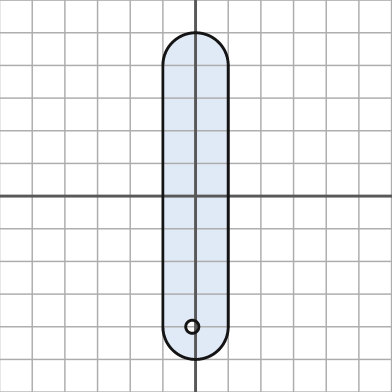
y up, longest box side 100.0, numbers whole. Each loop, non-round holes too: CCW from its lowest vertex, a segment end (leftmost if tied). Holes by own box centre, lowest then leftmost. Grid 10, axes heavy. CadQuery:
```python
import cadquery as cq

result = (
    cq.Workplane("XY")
    .moveTo(-10.0, -40.0)
    .threePointArc((0.0, -50.0), (10.0, -40.0))
    .lineTo(10.0, 40.0)
    .threePointArc((0.0, 50.0), (-10.0, 40.0))
    .close()
    .moveTo(-1.0, -40.0)
    .circle(2.0)
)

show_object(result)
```